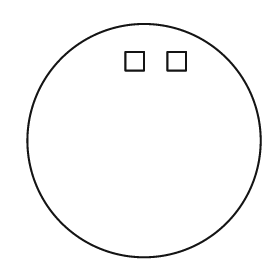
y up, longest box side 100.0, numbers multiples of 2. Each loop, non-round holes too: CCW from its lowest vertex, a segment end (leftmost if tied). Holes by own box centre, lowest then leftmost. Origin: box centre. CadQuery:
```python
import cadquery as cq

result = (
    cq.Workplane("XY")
    .moveTo(0.0, 0.0)
    .circle(50.0)
    .moveTo(-8.0, 30.0)
    .lineTo(0.0, 30.0)
    .lineTo(0.0, 38.0)
    .lineTo(-8.0, 38.0)
    .close()
    .moveTo(10.0, 30.0)
    .lineTo(18.0, 30.0)
    .lineTo(18.0, 38.0)
    .lineTo(10.0, 38.0)
    .close()
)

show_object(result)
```